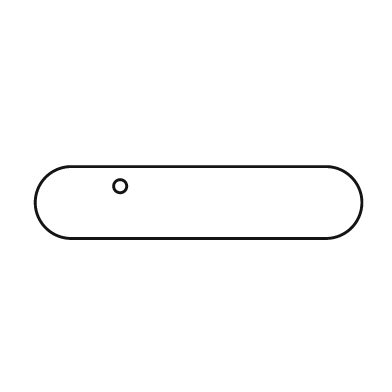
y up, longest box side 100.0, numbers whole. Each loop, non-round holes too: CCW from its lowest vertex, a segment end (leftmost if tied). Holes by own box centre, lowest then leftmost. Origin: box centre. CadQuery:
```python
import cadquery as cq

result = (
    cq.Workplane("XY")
    .moveTo(-39.0, -11.0)
    .lineTo(39.0, -11.0)
    .threePointArc((50.0, 0.0), (39.0, 11.0))
    .lineTo(-39.0, 11.0)
    .threePointArc((-50.0, 0.0), (-39.0, -11.0))
    .close()
    .moveTo(-24.0, 5.0)
    .circle(2.0)
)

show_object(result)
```